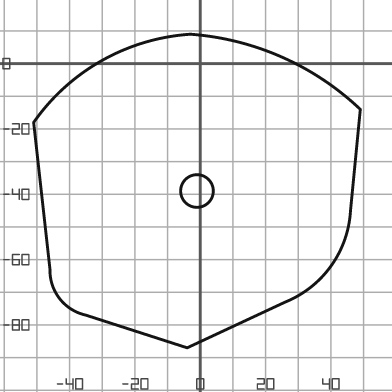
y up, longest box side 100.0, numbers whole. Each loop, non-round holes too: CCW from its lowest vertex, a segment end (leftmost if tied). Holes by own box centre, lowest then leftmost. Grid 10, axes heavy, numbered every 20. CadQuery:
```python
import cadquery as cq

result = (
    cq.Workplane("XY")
    .moveTo(-4.0, -87.0)
    .lineTo(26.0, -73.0)
    .threePointArc((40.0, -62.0), (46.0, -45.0))
    .lineTo(49.0, -14.0)
    .threePointArc((25.0, 2.0), (-3.0, 9.0))
    .threePointArc((-30.0, 1.0), (-51.0, -18.0))
    .lineTo(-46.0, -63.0)
    .threePointArc((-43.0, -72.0), (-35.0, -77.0))
    .close()
    .moveTo(-1.0, -39.0)
    .circle(5.0)
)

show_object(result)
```